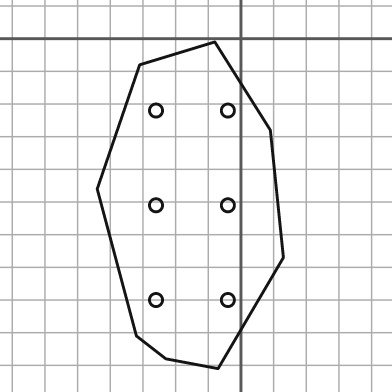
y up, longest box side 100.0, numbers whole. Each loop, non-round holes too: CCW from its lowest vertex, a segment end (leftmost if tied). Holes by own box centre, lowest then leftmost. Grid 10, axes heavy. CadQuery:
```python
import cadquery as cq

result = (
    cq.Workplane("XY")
    .moveTo(-7.0, -101.0)
    .lineTo(13.0, -67.0)
    .lineTo(9.0, -28.0)
    .lineTo(-8.0, -1.0)
    .lineTo(-31.0, -8.0)
    .lineTo(-44.0, -46.0)
    .lineTo(-32.0, -91.0)
    .lineTo(-23.0, -98.0)
    .close()
    .moveTo(-26.0, -80.0)
    .circle(2.0)
    .moveTo(-4.0, -80.0)
    .circle(2.0)
    .moveTo(-26.0, -51.0)
    .circle(2.0)
    .moveTo(-4.0, -51.0)
    .circle(2.0)
    .moveTo(-26.0, -22.0)
    .circle(2.0)
    .moveTo(-4.0, -22.0)
    .circle(2.0)
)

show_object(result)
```